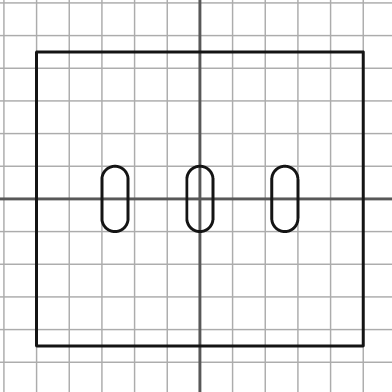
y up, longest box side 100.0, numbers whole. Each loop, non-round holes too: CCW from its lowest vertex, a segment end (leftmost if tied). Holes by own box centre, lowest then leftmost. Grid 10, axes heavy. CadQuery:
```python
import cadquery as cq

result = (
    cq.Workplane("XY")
    .moveTo(-50.0, -45.0)
    .lineTo(50.0, -45.0)
    .lineTo(50.0, 45.0)
    .lineTo(-50.0, 45.0)
    .close()
    .moveTo(-30.0, -6.0)
    .threePointArc((-26.0, -10.0), (-22.0, -6.0))
    .lineTo(-22.0, 6.0)
    .threePointArc((-26.0, 10.0), (-30.0, 6.0))
    .close()
    .moveTo(-4.0, -6.0)
    .threePointArc((0.0, -10.0), (4.0, -6.0))
    .lineTo(4.0, 6.0)
    .threePointArc((0.0, 10.0), (-4.0, 6.0))
    .close()
    .moveTo(22.0, -6.0)
    .threePointArc((26.0, -10.0), (30.0, -6.0))
    .lineTo(30.0, 6.0)
    .threePointArc((26.0, 10.0), (22.0, 6.0))
    .close()
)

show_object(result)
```